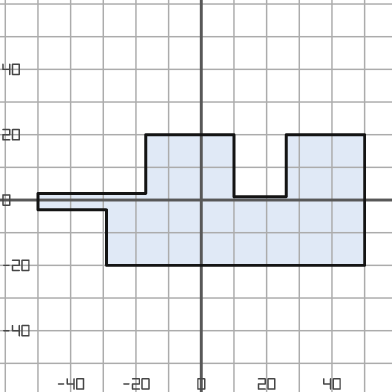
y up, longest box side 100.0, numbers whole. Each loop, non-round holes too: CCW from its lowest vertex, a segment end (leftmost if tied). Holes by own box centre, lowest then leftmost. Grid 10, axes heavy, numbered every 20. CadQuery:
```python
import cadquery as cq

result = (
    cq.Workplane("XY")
    .moveTo(-29.0, -20.0)
    .lineTo(50.0, -20.0)
    .lineTo(50.0, 20.0)
    .lineTo(26.0, 20.0)
    .lineTo(26.0, 1.0)
    .lineTo(10.0, 1.0)
    .lineTo(10.0, 20.0)
    .lineTo(-17.0, 20.0)
    .lineTo(-17.0, 2.0)
    .lineTo(-50.0, 2.0)
    .lineTo(-50.0, -3.0)
    .lineTo(-29.0, -3.0)
    .close()
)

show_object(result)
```